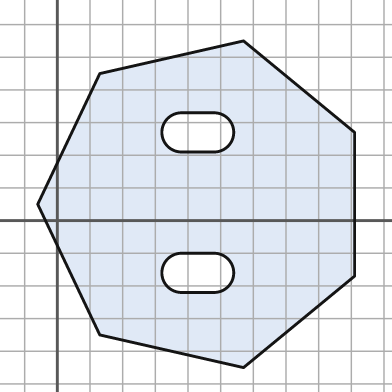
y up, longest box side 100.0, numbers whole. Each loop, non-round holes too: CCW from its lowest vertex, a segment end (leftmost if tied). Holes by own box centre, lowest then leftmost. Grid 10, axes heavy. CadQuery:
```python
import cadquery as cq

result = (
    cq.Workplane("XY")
    .moveTo(57.0, -45.0)
    .lineTo(91.0, -17.0)
    .lineTo(91.0, 27.0)
    .lineTo(57.0, 55.0)
    .lineTo(13.0, 45.0)
    .lineTo(-6.0, 5.0)
    .lineTo(13.0, -35.0)
    .close()
    .moveTo(38.0, -22.0)
    .lineTo(48.0, -22.0)
    .threePointArc((54.0, -16.0), (48.0, -10.0))
    .lineTo(38.0, -10.0)
    .threePointArc((32.0, -16.0), (38.0, -22.0))
    .close()
    .moveTo(38.0, 21.0)
    .lineTo(48.0, 21.0)
    .threePointArc((54.0, 27.0), (48.0, 33.0))
    .lineTo(38.0, 33.0)
    .threePointArc((32.0, 27.0), (38.0, 21.0))
    .close()
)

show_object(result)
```